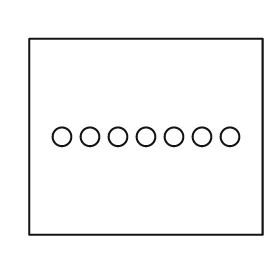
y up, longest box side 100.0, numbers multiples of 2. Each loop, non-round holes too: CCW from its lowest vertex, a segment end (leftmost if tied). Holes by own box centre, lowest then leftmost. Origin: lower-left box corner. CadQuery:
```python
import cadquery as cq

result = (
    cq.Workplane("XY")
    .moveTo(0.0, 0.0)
    .lineTo(100.0, 0.0)
    .lineTo(100.0, 84.0)
    .lineTo(0.0, 84.0)
    .close()
    .moveTo(14.0, 42.0)
    .circle(4.0)
    .moveTo(26.0, 42.0)
    .circle(4.0)
    .moveTo(38.0, 42.0)
    .circle(4.0)
    .moveTo(50.0, 42.0)
    .circle(4.0)
    .moveTo(62.0, 42.0)
    .circle(4.0)
    .moveTo(74.0, 42.0)
    .circle(4.0)
    .moveTo(86.0, 42.0)
    .circle(4.0)
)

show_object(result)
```